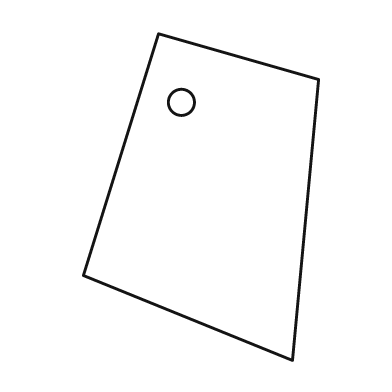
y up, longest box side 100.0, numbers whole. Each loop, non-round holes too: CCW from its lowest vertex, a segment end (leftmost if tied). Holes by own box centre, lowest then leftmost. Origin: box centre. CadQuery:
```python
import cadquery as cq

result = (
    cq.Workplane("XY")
    .moveTo(28.0, -50.0)
    .lineTo(36.0, 36.0)
    .lineTo(-13.0, 50.0)
    .lineTo(-36.0, -24.0)
    .close()
    .moveTo(-6.0, 29.0)
    .circle(4.0)
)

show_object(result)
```